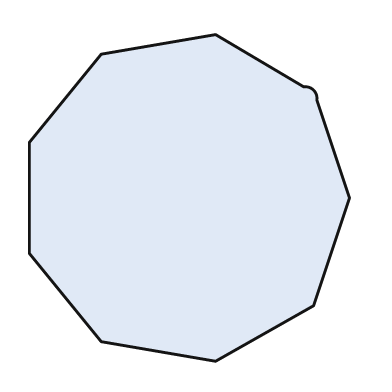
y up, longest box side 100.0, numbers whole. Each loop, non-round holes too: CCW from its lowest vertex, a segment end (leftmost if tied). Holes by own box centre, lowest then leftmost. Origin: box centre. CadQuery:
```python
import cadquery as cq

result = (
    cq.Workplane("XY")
    .moveTo(8.0, -50.0)
    .lineTo(38.0, -33.0)
    .lineTo(49.0, 0.0)
    .lineTo(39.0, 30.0)
    .threePointArc((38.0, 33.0), (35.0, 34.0))
    .lineTo(8.0, 50.0)
    .lineTo(-27.0, 44.0)
    .lineTo(-49.0, 17.0)
    .lineTo(-49.0, -17.0)
    .lineTo(-27.0, -44.0)
    .close()
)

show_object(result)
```